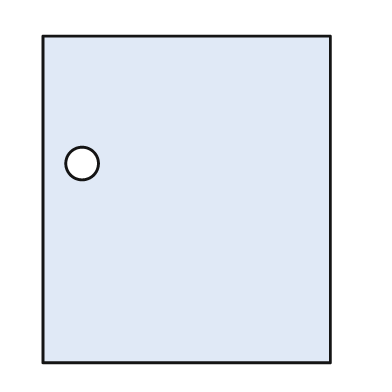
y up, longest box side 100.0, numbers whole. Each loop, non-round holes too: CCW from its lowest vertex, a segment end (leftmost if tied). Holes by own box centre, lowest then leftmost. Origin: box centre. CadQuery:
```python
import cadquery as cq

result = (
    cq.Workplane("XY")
    .moveTo(-44.0, -50.0)
    .lineTo(44.0, -50.0)
    .lineTo(44.0, 50.0)
    .lineTo(-44.0, 50.0)
    .close()
    .moveTo(-32.0, 11.0)
    .circle(5.0)
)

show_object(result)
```